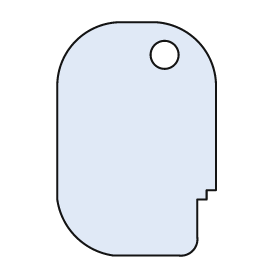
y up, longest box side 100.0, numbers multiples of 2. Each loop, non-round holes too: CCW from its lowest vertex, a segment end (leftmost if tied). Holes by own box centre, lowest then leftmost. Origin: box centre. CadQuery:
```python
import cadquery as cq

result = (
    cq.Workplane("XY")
    .moveTo(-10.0, -50.0)
    .lineTo(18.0, -50.0)
    .threePointArc((24.0, -48.0), (26.0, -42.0))
    .lineTo(26.0, -26.0)
    .lineTo(30.0, -26.0)
    .lineTo(30.0, -22.0)
    .lineTo(34.0, -22.0)
    .lineTo(34.0, 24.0)
    .threePointArc((26.0, 42.0), (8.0, 50.0))
    .lineTo(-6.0, 50.0)
    .threePointArc((-26.0, 42.0), (-34.0, 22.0))
    .lineTo(-34.0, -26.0)
    .threePointArc((-26.0, -42.0), (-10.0, -50.0))
    .close()
    .moveTo(12.0, 36.0)
    .circle(6.0)
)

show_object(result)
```